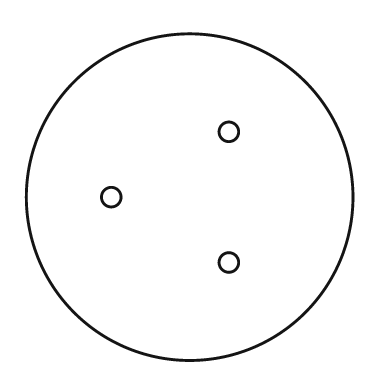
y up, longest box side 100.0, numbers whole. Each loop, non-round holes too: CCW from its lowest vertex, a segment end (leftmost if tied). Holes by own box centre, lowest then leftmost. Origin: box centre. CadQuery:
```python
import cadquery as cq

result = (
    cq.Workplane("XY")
    .moveTo(0.0, 0.0)
    .circle(50.0)
    .moveTo(12.0, -20.0)
    .circle(3.0)
    .moveTo(-24.0, 0.0)
    .circle(3.0)
    .moveTo(12.0, 20.0)
    .circle(3.0)
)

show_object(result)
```